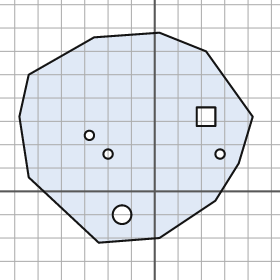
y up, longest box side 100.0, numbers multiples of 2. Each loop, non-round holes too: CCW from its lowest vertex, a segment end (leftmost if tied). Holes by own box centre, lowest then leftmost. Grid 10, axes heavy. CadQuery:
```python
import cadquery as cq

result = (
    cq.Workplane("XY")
    .moveTo(-24.0, -22.0)
    .lineTo(2.0, -20.0)
    .lineTo(26.0, -4.0)
    .lineTo(36.0, 12.0)
    .lineTo(42.0, 32.0)
    .lineTo(22.0, 60.0)
    .lineTo(2.0, 68.0)
    .lineTo(-26.0, 66.0)
    .lineTo(-54.0, 50.0)
    .lineTo(-58.0, 32.0)
    .lineTo(-54.0, 6.0)
    .close()
    .moveTo(-14.0, -10.0)
    .circle(4.0)
    .moveTo(-20.0, 16.0)
    .circle(2.0)
    .moveTo(28.0, 16.0)
    .circle(2.0)
    .moveTo(-28.0, 24.0)
    .circle(2.0)
    .moveTo(18.0, 28.0)
    .lineTo(26.0, 28.0)
    .lineTo(26.0, 36.0)
    .lineTo(18.0, 36.0)
    .close()
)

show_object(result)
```